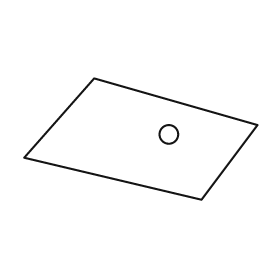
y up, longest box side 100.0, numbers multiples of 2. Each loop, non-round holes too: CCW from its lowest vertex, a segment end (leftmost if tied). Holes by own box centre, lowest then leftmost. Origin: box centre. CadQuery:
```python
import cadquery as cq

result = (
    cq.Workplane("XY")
    .moveTo(26.0, -26.0)
    .lineTo(50.0, 6.0)
    .lineTo(-20.0, 26.0)
    .lineTo(-50.0, -8.0)
    .close()
    .moveTo(12.0, 2.0)
    .circle(4.0)
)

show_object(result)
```